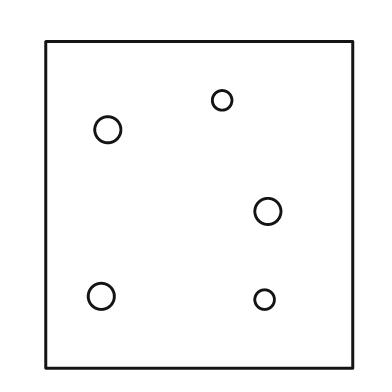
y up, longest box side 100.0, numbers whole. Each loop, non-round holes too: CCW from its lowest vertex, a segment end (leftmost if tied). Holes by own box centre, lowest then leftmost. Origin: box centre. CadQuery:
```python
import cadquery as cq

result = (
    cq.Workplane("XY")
    .moveTo(-47.0, -50.0)
    .lineTo(47.0, -50.0)
    .lineTo(47.0, 50.0)
    .lineTo(-47.0, 50.0)
    .close()
    .moveTo(20.0, -29.0)
    .circle(3.0)
    .moveTo(-30.0, -28.0)
    .circle(4.0)
    .moveTo(21.0, -2.0)
    .circle(4.0)
    .moveTo(-28.0, 23.0)
    .circle(4.0)
    .moveTo(7.0, 32.0)
    .circle(3.0)
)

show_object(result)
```